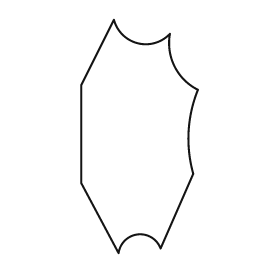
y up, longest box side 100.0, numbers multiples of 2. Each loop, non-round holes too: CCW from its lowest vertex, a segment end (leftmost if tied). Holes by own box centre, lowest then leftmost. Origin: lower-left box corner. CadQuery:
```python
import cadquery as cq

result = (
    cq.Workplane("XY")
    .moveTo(16.0, 0.0)
    .threePointArc((24.0, 8.0), (34.0, 2.0))
    .lineTo(48.0, 34.0)
    .threePointArc((46.0, 52.0), (50.0, 70.0))
    .threePointArc((40.0, 80.0), (38.0, 94.0))
    .threePointArc((24.0, 90.0), (14.0, 100.0))
    .lineTo(0.0, 72.0)
    .lineTo(0.0, 30.0)
    .close()
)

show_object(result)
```